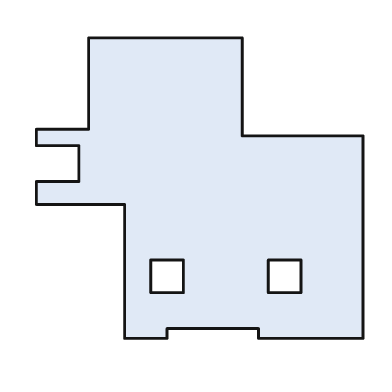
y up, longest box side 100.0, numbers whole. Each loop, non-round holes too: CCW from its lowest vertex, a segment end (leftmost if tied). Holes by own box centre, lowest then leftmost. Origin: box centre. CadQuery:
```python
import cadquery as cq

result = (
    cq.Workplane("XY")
    .moveTo(-23.0, -46.0)
    .lineTo(-10.0, -46.0)
    .lineTo(-10.0, -43.0)
    .lineTo(18.0, -43.0)
    .lineTo(18.0, -46.0)
    .lineTo(50.0, -46.0)
    .lineTo(50.0, 16.0)
    .lineTo(13.0, 16.0)
    .lineTo(13.0, 46.0)
    .lineTo(-34.0, 46.0)
    .lineTo(-34.0, 18.0)
    .lineTo(-50.0, 18.0)
    .lineTo(-50.0, 13.0)
    .lineTo(-37.0, 13.0)
    .lineTo(-37.0, 2.0)
    .lineTo(-50.0, 2.0)
    .lineTo(-50.0, -5.0)
    .lineTo(-23.0, -5.0)
    .close()
    .moveTo(-15.0, -32.0)
    .lineTo(-5.0, -32.0)
    .lineTo(-5.0, -22.0)
    .lineTo(-15.0, -22.0)
    .close()
    .moveTo(21.0, -32.0)
    .lineTo(31.0, -32.0)
    .lineTo(31.0, -22.0)
    .lineTo(21.0, -22.0)
    .close()
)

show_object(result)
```